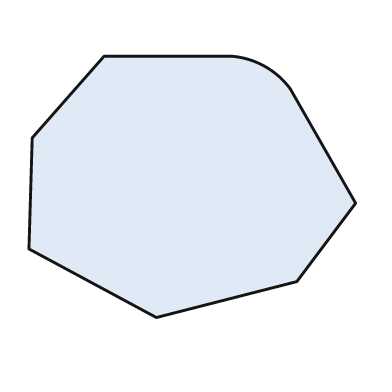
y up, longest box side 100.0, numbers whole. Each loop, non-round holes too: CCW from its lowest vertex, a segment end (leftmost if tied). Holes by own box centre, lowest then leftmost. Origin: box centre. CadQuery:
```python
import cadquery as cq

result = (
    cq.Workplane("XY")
    .moveTo(-11.0, -40.0)
    .lineTo(32.0, -29.0)
    .lineTo(50.0, -5.0)
    .lineTo(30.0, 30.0)
    .threePointArc((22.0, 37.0), (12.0, 40.0))
    .lineTo(-27.0, 40.0)
    .lineTo(-49.0, 15.0)
    .lineTo(-50.0, -19.0)
    .close()
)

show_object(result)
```